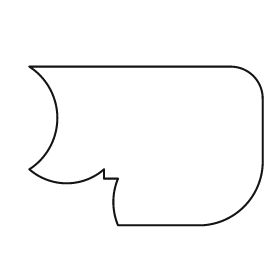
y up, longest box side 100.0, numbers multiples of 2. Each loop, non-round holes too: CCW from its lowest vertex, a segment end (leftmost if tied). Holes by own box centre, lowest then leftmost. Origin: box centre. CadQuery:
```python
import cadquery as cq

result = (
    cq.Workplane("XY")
    .moveTo(-12.0, -34.0)
    .lineTo(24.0, -34.0)
    .threePointArc((42.0, -26.0), (50.0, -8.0))
    .lineTo(50.0, 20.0)
    .threePointArc((46.0, 30.0), (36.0, 34.0))
    .lineTo(-50.0, 34.0)
    .threePointArc((-38.0, 12.0), (-50.0, -10.0))
    .threePointArc((-34.0, -16.0), (-18.0, -10.0))
    .lineTo(-18.0, -14.0)
    .lineTo(-12.0, -14.0)
    .threePointArc((-14.0, -24.0), (-12.0, -34.0))
    .close()
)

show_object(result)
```